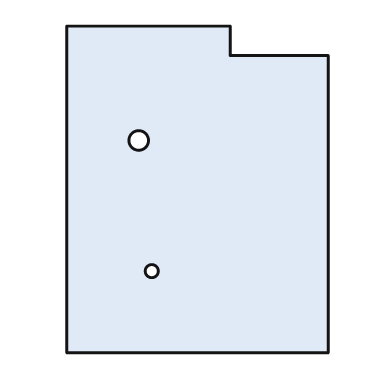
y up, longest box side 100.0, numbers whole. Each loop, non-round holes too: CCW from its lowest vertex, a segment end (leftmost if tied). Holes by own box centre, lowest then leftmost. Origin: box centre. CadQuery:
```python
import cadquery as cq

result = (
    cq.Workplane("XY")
    .moveTo(-40.0, -50.0)
    .lineTo(40.0, -50.0)
    .lineTo(40.0, 41.0)
    .lineTo(10.0, 41.0)
    .lineTo(10.0, 50.0)
    .lineTo(-40.0, 50.0)
    .close()
    .moveTo(-14.0, -25.0)
    .circle(2.0)
    .moveTo(-18.0, 15.0)
    .circle(3.0)
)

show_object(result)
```